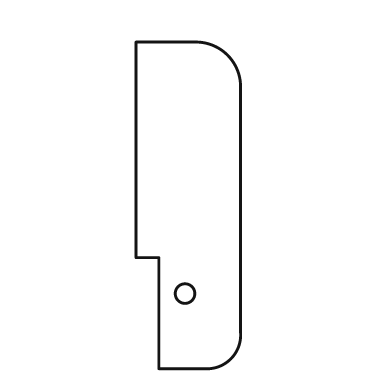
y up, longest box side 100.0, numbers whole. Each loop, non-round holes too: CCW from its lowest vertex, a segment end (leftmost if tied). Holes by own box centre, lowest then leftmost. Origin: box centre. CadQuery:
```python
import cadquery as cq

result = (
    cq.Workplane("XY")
    .moveTo(-9.0, -50.0)
    .lineTo(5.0, -50.0)
    .threePointArc((13.0, -47.0), (16.0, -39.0))
    .lineTo(16.0, 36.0)
    .threePointArc((12.0, 46.0), (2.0, 50.0))
    .lineTo(-16.0, 50.0)
    .lineTo(-16.0, -16.0)
    .lineTo(-9.0, -16.0)
    .close()
    .moveTo(-1.0, -27.0)
    .circle(3.0)
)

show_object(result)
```